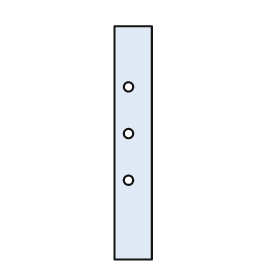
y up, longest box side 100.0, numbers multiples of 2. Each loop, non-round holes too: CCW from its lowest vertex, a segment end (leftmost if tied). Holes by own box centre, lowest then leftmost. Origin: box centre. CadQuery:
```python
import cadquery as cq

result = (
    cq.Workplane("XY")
    .moveTo(-8.0, -50.0)
    .lineTo(8.0, -50.0)
    .lineTo(8.0, 50.0)
    .lineTo(-8.0, 50.0)
    .close()
    .moveTo(-2.0, -16.0)
    .circle(2.0)
    .moveTo(-2.0, 4.0)
    .circle(2.0)
    .moveTo(-2.0, 24.0)
    .circle(2.0)
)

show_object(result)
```